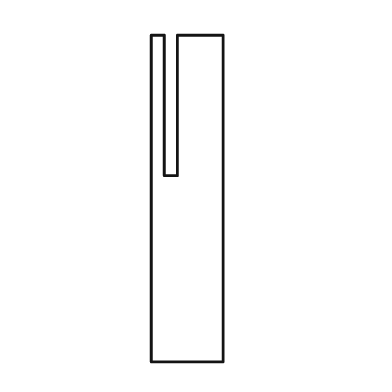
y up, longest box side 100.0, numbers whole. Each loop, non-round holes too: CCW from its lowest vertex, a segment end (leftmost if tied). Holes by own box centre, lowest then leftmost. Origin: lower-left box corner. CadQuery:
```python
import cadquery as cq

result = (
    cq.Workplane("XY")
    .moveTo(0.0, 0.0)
    .lineTo(22.0, 0.0)
    .lineTo(22.0, 100.0)
    .lineTo(8.0, 100.0)
    .lineTo(8.0, 57.0)
    .lineTo(4.0, 57.0)
    .lineTo(4.0, 100.0)
    .lineTo(0.0, 100.0)
    .close()
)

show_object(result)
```